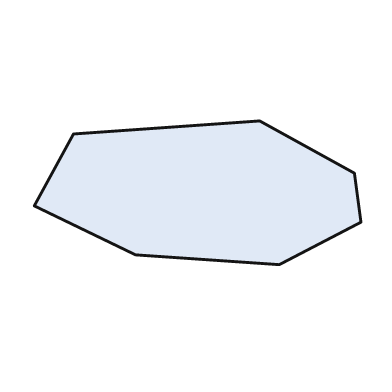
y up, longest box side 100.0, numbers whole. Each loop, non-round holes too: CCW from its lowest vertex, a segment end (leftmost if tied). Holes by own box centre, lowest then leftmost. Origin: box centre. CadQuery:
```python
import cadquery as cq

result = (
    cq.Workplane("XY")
    .moveTo(25.0, -22.0)
    .lineTo(50.0, -9.0)
    .lineTo(48.0, 6.0)
    .lineTo(19.0, 22.0)
    .lineTo(-38.0, 18.0)
    .lineTo(-50.0, -4.0)
    .lineTo(-19.0, -19.0)
    .close()
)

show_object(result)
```